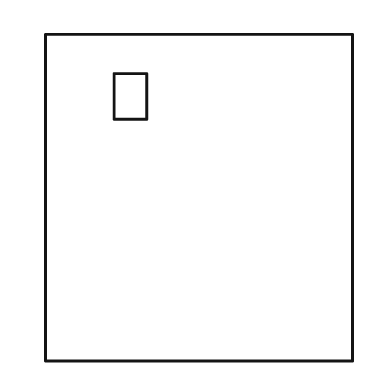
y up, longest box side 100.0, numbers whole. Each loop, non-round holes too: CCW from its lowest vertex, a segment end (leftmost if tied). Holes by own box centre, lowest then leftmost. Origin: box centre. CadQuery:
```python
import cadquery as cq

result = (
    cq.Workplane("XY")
    .moveTo(-47.0, -50.0)
    .lineTo(47.0, -50.0)
    .lineTo(47.0, 50.0)
    .lineTo(-47.0, 50.0)
    .close()
    .moveTo(-26.0, 24.0)
    .lineTo(-16.0, 24.0)
    .lineTo(-16.0, 38.0)
    .lineTo(-26.0, 38.0)
    .close()
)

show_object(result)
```